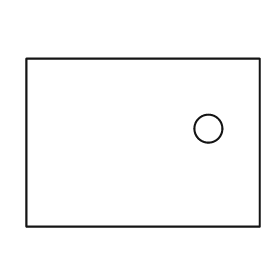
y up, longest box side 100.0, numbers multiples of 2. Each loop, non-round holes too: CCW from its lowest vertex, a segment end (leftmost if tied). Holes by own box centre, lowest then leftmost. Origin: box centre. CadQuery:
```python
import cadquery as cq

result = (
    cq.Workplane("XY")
    .moveTo(-50.0, -36.0)
    .lineTo(50.0, -36.0)
    .lineTo(50.0, 36.0)
    .lineTo(-50.0, 36.0)
    .close()
    .moveTo(28.0, 6.0)
    .circle(6.0)
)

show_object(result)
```